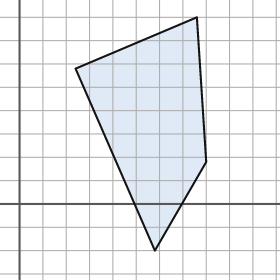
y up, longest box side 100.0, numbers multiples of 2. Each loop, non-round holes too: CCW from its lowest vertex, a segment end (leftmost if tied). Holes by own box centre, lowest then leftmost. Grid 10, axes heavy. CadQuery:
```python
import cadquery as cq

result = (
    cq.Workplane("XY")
    .moveTo(58.0, -20.0)
    .lineTo(80.0, 18.0)
    .lineTo(76.0, 80.0)
    .lineTo(24.0, 58.0)
    .close()
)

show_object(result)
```